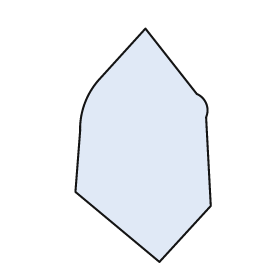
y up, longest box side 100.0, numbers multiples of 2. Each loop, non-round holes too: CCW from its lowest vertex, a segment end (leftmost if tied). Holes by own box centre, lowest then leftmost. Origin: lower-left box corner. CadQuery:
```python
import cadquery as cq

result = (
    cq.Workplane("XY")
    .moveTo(36.0, 0.0)
    .lineTo(58.0, 24.0)
    .lineTo(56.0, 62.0)
    .threePointArc((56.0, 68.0), (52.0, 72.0))
    .lineTo(30.0, 100.0)
    .lineTo(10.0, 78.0)
    .threePointArc((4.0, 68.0), (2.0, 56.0))
    .lineTo(0.0, 30.0)
    .close()
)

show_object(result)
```